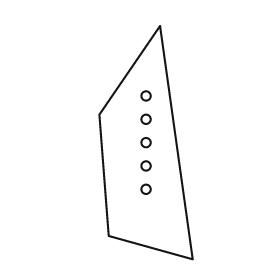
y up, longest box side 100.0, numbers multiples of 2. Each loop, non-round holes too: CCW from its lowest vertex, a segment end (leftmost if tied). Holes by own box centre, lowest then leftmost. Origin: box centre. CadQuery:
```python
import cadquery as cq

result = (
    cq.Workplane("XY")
    .moveTo(20.0, -50.0)
    .lineTo(6.0, 50.0)
    .lineTo(-20.0, 12.0)
    .lineTo(-16.0, -40.0)
    .close()
    .moveTo(0.0, -20.0)
    .circle(2.0)
    .moveTo(0.0, -10.0)
    .circle(2.0)
    .moveTo(0.0, 0.0)
    .circle(2.0)
    .moveTo(0.0, 10.0)
    .circle(2.0)
    .moveTo(0.0, 20.0)
    .circle(2.0)
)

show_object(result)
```